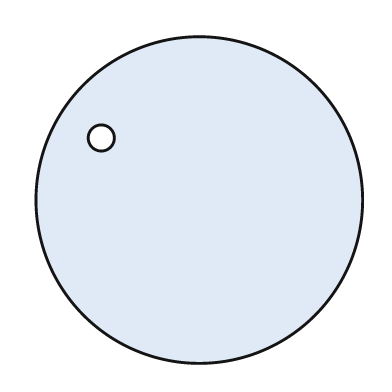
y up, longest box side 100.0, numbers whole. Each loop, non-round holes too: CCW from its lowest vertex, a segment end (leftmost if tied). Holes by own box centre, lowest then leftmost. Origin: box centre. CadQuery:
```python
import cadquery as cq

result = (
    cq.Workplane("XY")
    .moveTo(0.0, 0.0)
    .circle(50.0)
    .moveTo(-30.0, 19.0)
    .circle(4.0)
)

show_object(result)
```